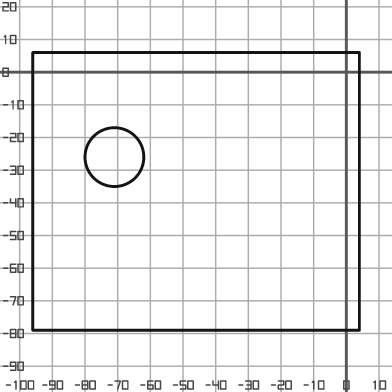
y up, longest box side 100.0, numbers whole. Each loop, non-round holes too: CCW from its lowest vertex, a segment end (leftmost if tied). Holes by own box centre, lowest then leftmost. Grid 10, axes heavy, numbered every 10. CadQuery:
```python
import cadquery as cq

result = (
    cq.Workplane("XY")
    .moveTo(-96.0, -79.0)
    .lineTo(4.0, -79.0)
    .lineTo(4.0, 6.0)
    .lineTo(-96.0, 6.0)
    .close()
    .moveTo(-71.0, -26.0)
    .circle(9.0)
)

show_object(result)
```